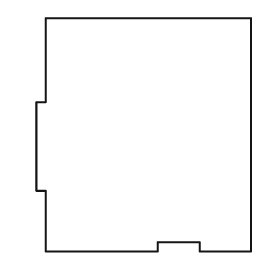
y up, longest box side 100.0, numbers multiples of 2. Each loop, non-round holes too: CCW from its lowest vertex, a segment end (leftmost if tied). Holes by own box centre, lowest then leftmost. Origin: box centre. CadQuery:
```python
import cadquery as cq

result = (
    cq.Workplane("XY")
    .moveTo(-42.0, -50.0)
    .lineTo(6.0, -50.0)
    .lineTo(6.0, -46.0)
    .lineTo(24.0, -46.0)
    .lineTo(24.0, -50.0)
    .lineTo(46.0, -50.0)
    .lineTo(46.0, 50.0)
    .lineTo(-42.0, 50.0)
    .lineTo(-42.0, 14.0)
    .lineTo(-46.0, 14.0)
    .lineTo(-46.0, -24.0)
    .lineTo(-42.0, -24.0)
    .close()
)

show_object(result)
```